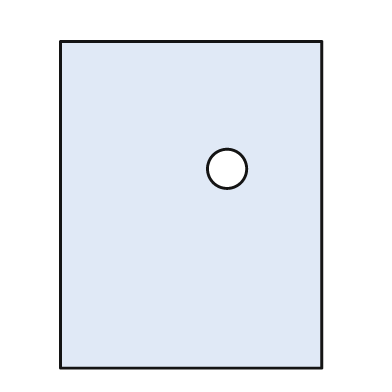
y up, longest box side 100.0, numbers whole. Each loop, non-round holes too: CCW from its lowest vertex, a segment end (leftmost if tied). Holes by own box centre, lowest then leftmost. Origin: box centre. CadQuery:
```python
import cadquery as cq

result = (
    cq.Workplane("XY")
    .moveTo(-40.0, -50.0)
    .lineTo(40.0, -50.0)
    .lineTo(40.0, 50.0)
    .lineTo(-40.0, 50.0)
    .close()
    .moveTo(11.0, 11.0)
    .circle(6.0)
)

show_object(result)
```